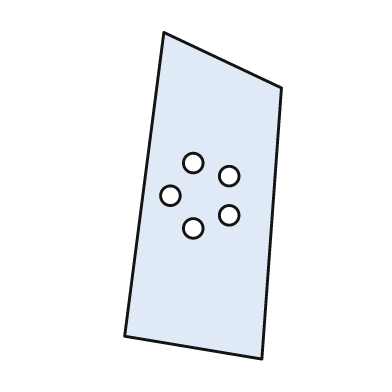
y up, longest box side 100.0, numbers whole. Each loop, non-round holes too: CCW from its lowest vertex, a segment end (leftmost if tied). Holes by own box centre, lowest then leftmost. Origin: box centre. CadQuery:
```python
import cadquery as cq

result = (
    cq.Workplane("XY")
    .moveTo(18.0, -50.0)
    .lineTo(24.0, 33.0)
    .lineTo(-12.0, 50.0)
    .lineTo(-24.0, -43.0)
    .close()
    .moveTo(-3.0, -10.0)
    .circle(3.0)
    .moveTo(8.0, -6.0)
    .circle(3.0)
    .moveTo(-10.0, 0.0)
    .circle(3.0)
    .moveTo(8.0, 6.0)
    .circle(3.0)
    .moveTo(-3.0, 10.0)
    .circle(3.0)
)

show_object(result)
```